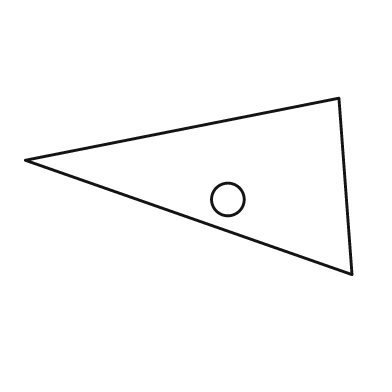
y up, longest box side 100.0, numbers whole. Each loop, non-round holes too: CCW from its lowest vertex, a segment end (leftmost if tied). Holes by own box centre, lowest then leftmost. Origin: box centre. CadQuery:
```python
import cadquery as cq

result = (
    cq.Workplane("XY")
    .moveTo(50.0, -27.0)
    .lineTo(46.0, 27.0)
    .lineTo(-50.0, 8.0)
    .close()
    .moveTo(12.0, -4.0)
    .circle(5.0)
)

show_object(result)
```